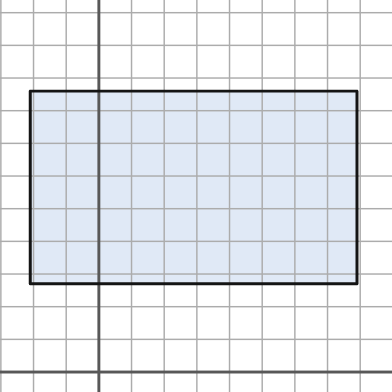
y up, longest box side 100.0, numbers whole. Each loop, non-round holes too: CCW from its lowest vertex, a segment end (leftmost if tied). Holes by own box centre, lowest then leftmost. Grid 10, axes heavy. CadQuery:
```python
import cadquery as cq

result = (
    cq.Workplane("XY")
    .moveTo(-21.0, 27.0)
    .lineTo(79.0, 27.0)
    .lineTo(79.0, 86.0)
    .lineTo(-21.0, 86.0)
    .close()
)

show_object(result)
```